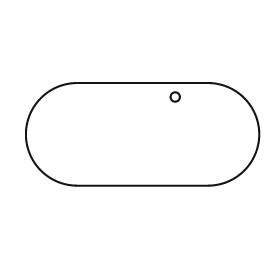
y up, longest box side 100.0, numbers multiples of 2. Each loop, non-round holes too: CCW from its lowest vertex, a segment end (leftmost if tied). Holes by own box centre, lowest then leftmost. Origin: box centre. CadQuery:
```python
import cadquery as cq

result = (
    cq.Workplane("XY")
    .moveTo(-28.0, -22.0)
    .lineTo(28.0, -22.0)
    .threePointArc((50.0, 0.0), (28.0, 22.0))
    .lineTo(-28.0, 22.0)
    .threePointArc((-50.0, 0.0), (-28.0, -22.0))
    .close()
    .moveTo(14.0, 16.0)
    .circle(2.0)
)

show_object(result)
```